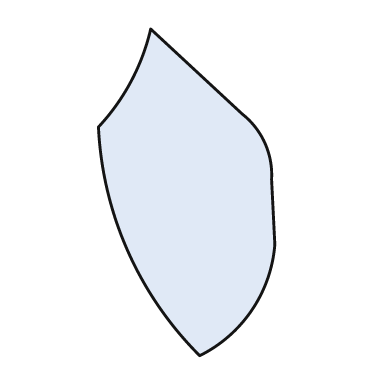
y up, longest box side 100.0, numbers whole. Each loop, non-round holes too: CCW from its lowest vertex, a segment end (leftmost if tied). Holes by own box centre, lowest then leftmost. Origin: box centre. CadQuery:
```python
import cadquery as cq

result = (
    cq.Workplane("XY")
    .moveTo(4.0, -50.0)
    .threePointArc((20.0, -36.0), (27.0, -16.0))
    .lineTo(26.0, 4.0)
    .threePointArc((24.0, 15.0), (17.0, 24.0))
    .lineTo(-11.0, 50.0)
    .threePointArc((-17.0, 34.0), (-27.0, 20.0))
    .threePointArc((-18.0, -18.0), (4.0, -50.0))
    .close()
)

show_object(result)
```